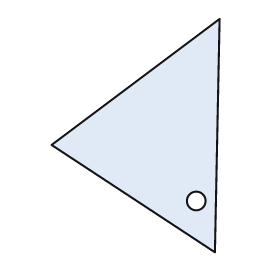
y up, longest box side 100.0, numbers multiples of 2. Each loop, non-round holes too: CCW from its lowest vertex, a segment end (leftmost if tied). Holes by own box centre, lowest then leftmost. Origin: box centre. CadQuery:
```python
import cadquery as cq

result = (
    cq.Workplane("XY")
    .moveTo(34.0, -50.0)
    .lineTo(36.0, 50.0)
    .lineTo(-36.0, -4.0)
    .close()
    .moveTo(26.0, -28.0)
    .circle(4.0)
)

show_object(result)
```